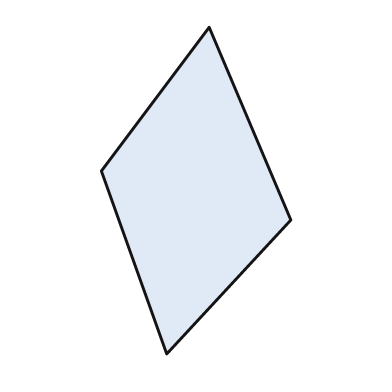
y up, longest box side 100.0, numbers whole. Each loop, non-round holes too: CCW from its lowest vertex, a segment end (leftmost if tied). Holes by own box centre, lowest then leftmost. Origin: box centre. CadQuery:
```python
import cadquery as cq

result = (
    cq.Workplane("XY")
    .moveTo(-9.0, -50.0)
    .lineTo(29.0, -9.0)
    .lineTo(4.0, 50.0)
    .lineTo(-29.0, 6.0)
    .close()
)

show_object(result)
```